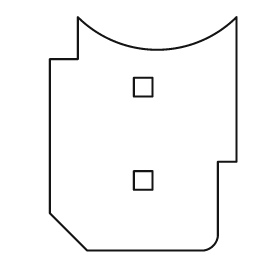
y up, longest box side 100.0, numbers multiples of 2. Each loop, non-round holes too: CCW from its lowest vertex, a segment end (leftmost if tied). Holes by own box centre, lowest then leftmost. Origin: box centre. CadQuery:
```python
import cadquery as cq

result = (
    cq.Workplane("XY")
    .moveTo(-24.0, -50.0)
    .lineTo(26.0, -50.0)
    .threePointArc((30.0, -48.0), (32.0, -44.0))
    .lineTo(32.0, -12.0)
    .lineTo(40.0, -12.0)
    .lineTo(40.0, 50.0)
    .threePointArc((6.0, 36.0), (-28.0, 50.0))
    .lineTo(-28.0, 32.0)
    .lineTo(-40.0, 32.0)
    .lineTo(-40.0, -34.0)
    .close()
    .moveTo(-4.0, -24.0)
    .lineTo(4.0, -24.0)
    .lineTo(4.0, -16.0)
    .lineTo(-4.0, -16.0)
    .close()
    .moveTo(-4.0, 16.0)
    .lineTo(4.0, 16.0)
    .lineTo(4.0, 24.0)
    .lineTo(-4.0, 24.0)
    .close()
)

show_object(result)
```